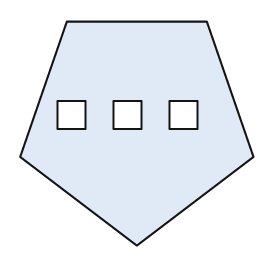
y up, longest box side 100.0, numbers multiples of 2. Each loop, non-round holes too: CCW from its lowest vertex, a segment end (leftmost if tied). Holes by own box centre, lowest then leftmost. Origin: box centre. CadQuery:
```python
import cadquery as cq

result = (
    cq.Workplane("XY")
    .moveTo(0.0, -48.0)
    .lineTo(50.0, -10.0)
    .lineTo(30.0, 48.0)
    .lineTo(-30.0, 48.0)
    .lineTo(-50.0, -10.0)
    .close()
    .moveTo(-34.0, 2.0)
    .lineTo(-22.0, 2.0)
    .lineTo(-22.0, 14.0)
    .lineTo(-34.0, 14.0)
    .close()
    .moveTo(-10.0, 2.0)
    .lineTo(2.0, 2.0)
    .lineTo(2.0, 14.0)
    .lineTo(-10.0, 14.0)
    .close()
    .moveTo(14.0, 2.0)
    .lineTo(26.0, 2.0)
    .lineTo(26.0, 14.0)
    .lineTo(14.0, 14.0)
    .close()
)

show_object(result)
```